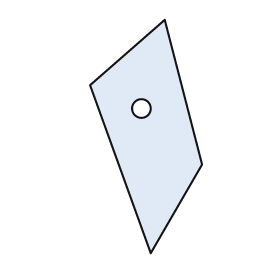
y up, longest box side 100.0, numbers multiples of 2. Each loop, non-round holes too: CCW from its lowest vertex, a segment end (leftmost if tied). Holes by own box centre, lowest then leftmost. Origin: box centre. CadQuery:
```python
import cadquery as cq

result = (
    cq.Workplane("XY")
    .moveTo(2.0, -50.0)
    .lineTo(24.0, -12.0)
    .lineTo(8.0, 50.0)
    .lineTo(-24.0, 22.0)
    .close()
    .moveTo(-2.0, 12.0)
    .circle(4.0)
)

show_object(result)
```